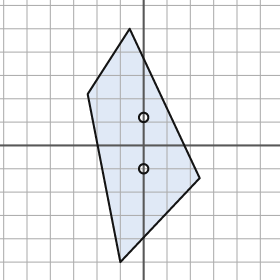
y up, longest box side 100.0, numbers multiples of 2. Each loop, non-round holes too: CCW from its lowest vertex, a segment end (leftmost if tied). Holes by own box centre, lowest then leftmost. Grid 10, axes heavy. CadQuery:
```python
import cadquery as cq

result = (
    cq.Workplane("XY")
    .moveTo(-10.0, -50.0)
    .lineTo(24.0, -14.0)
    .lineTo(-6.0, 50.0)
    .lineTo(-24.0, 22.0)
    .close()
    .moveTo(0.0, -10.0)
    .circle(2.0)
    .moveTo(0.0, 12.0)
    .circle(2.0)
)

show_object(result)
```